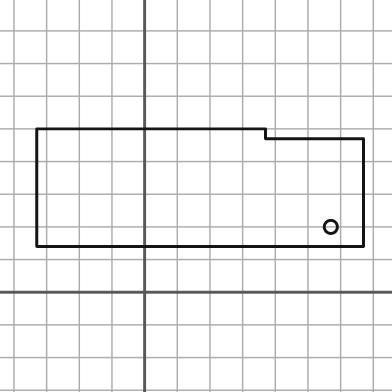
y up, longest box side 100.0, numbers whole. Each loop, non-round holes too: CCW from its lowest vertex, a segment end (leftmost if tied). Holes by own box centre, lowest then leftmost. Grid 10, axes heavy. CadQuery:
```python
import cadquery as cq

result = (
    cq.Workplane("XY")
    .moveTo(-33.0, 14.0)
    .lineTo(67.0, 14.0)
    .lineTo(67.0, 47.0)
    .lineTo(37.0, 47.0)
    .lineTo(37.0, 50.0)
    .lineTo(-33.0, 50.0)
    .close()
    .moveTo(57.0, 20.0)
    .circle(2.0)
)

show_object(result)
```